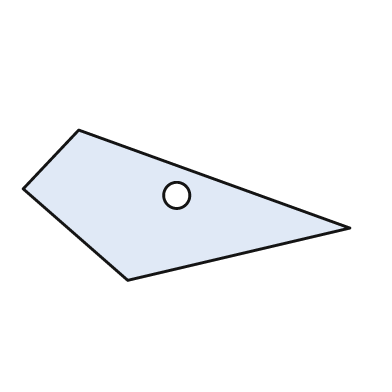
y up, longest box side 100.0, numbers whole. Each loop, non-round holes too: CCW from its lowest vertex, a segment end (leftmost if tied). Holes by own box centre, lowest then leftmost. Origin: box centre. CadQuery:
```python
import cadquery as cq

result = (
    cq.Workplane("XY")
    .moveTo(-18.0, -23.0)
    .lineTo(50.0, -7.0)
    .lineTo(-33.0, 23.0)
    .lineTo(-50.0, 5.0)
    .close()
    .moveTo(-3.0, 3.0)
    .circle(4.0)
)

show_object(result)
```